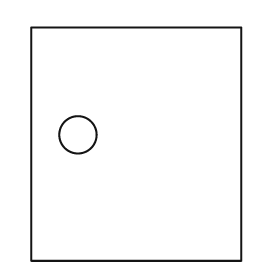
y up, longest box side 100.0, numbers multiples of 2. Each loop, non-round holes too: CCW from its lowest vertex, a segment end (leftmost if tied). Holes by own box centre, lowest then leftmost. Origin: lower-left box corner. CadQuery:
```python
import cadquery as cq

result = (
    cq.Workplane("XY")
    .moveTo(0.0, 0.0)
    .lineTo(90.0, 0.0)
    .lineTo(90.0, 100.0)
    .lineTo(0.0, 100.0)
    .close()
    .moveTo(20.0, 54.0)
    .circle(8.0)
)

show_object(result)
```